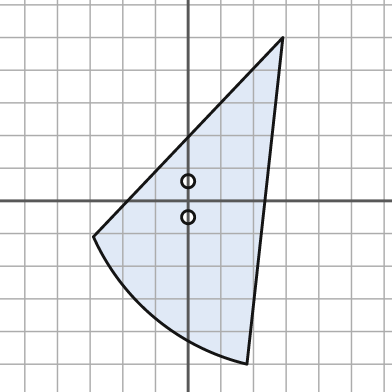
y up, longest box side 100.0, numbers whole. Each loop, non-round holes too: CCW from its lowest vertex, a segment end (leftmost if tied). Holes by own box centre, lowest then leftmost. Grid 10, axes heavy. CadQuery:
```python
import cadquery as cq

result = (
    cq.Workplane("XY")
    .moveTo(18.0, -50.0)
    .lineTo(29.0, 50.0)
    .lineTo(-29.0, -11.0)
    .threePointArc((-10.0, -36.0), (18.0, -50.0))
    .close()
    .moveTo(0.0, -5.0)
    .circle(2.0)
    .moveTo(0.0, 6.0)
    .circle(2.0)
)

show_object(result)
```